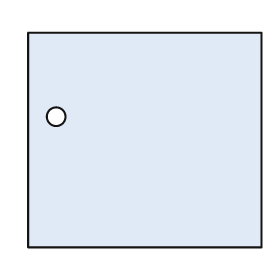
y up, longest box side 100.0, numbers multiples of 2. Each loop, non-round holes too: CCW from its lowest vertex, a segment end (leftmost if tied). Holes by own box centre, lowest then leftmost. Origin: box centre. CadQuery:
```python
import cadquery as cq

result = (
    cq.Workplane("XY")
    .moveTo(-50.0, -46.0)
    .lineTo(50.0, -46.0)
    .lineTo(50.0, 46.0)
    .lineTo(-50.0, 46.0)
    .close()
    .moveTo(-38.0, 10.0)
    .circle(4.0)
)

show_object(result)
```